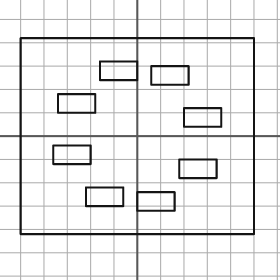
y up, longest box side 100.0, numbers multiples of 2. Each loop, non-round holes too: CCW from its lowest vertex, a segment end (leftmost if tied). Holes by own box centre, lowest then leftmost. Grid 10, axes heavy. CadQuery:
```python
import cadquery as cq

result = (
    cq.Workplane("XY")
    .moveTo(-50.0, -42.0)
    .lineTo(50.0, -42.0)
    .lineTo(50.0, 42.0)
    .lineTo(-50.0, 42.0)
    .close()
    .moveTo(0.0, -32.0)
    .lineTo(16.0, -32.0)
    .lineTo(16.0, -24.0)
    .lineTo(0.0, -24.0)
    .close()
    .moveTo(-22.0, -30.0)
    .lineTo(-6.0, -30.0)
    .lineTo(-6.0, -22.0)
    .lineTo(-22.0, -22.0)
    .close()
    .moveTo(18.0, -18.0)
    .lineTo(34.0, -18.0)
    .lineTo(34.0, -10.0)
    .lineTo(18.0, -10.0)
    .close()
    .moveTo(-36.0, -12.0)
    .lineTo(-20.0, -12.0)
    .lineTo(-20.0, -4.0)
    .lineTo(-36.0, -4.0)
    .close()
    .moveTo(20.0, 4.0)
    .lineTo(36.0, 4.0)
    .lineTo(36.0, 12.0)
    .lineTo(20.0, 12.0)
    .close()
    .moveTo(-34.0, 10.0)
    .lineTo(-18.0, 10.0)
    .lineTo(-18.0, 18.0)
    .lineTo(-34.0, 18.0)
    .close()
    .moveTo(6.0, 22.0)
    .lineTo(22.0, 22.0)
    .lineTo(22.0, 30.0)
    .lineTo(6.0, 30.0)
    .close()
    .moveTo(-16.0, 24.0)
    .lineTo(0.0, 24.0)
    .lineTo(0.0, 32.0)
    .lineTo(-16.0, 32.0)
    .close()
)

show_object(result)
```